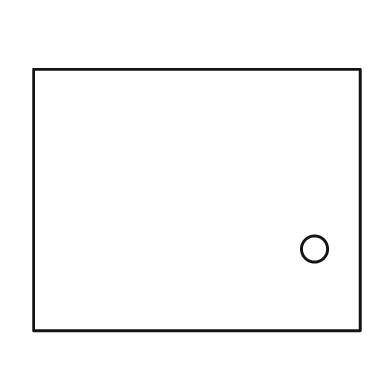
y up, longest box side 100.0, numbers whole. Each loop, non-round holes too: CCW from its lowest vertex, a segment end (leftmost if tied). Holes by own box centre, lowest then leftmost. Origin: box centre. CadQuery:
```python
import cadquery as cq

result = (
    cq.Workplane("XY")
    .moveTo(-50.0, -40.0)
    .lineTo(50.0, -40.0)
    .lineTo(50.0, 40.0)
    .lineTo(-50.0, 40.0)
    .close()
    .moveTo(36.0, -15.0)
    .circle(4.0)
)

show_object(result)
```